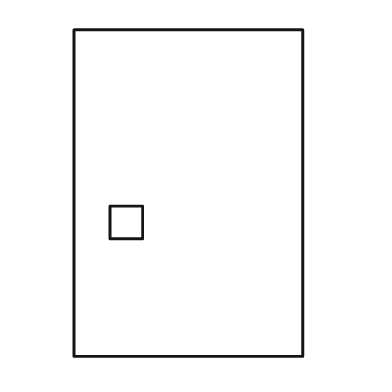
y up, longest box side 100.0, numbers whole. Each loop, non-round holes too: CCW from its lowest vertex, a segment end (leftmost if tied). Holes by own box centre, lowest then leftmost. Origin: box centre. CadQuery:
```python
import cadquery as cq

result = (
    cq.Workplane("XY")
    .moveTo(-35.0, -50.0)
    .lineTo(35.0, -50.0)
    .lineTo(35.0, 50.0)
    .lineTo(-35.0, 50.0)
    .close()
    .moveTo(-24.0, -14.0)
    .lineTo(-14.0, -14.0)
    .lineTo(-14.0, -4.0)
    .lineTo(-24.0, -4.0)
    .close()
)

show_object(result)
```